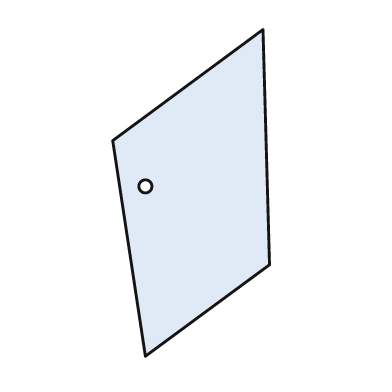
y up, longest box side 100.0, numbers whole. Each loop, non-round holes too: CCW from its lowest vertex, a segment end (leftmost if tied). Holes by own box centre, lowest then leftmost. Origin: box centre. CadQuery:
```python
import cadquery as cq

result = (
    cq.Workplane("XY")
    .moveTo(-14.0, -50.0)
    .lineTo(24.0, -22.0)
    .lineTo(22.0, 50.0)
    .lineTo(-24.0, 16.0)
    .close()
    .moveTo(-14.0, 2.0)
    .circle(2.0)
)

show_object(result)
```